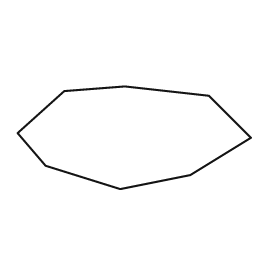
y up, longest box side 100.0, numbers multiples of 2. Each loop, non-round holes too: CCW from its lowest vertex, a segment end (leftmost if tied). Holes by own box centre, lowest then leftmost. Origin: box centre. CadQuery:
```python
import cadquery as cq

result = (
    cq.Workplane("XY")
    .moveTo(-6.0, -22.0)
    .lineTo(24.0, -16.0)
    .lineTo(50.0, 0.0)
    .lineTo(32.0, 18.0)
    .lineTo(-4.0, 22.0)
    .lineTo(-30.0, 20.0)
    .lineTo(-50.0, 2.0)
    .lineTo(-38.0, -12.0)
    .close()
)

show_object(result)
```